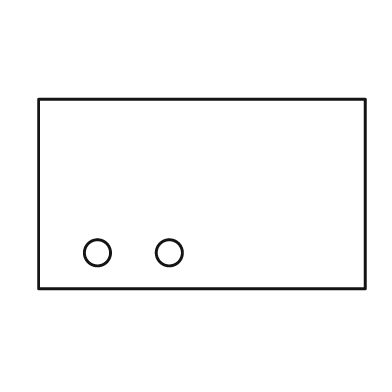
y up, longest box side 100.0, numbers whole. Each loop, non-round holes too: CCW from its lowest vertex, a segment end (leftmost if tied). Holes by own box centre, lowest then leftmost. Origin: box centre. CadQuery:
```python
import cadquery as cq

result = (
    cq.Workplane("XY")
    .moveTo(-50.0, -29.0)
    .lineTo(50.0, -29.0)
    .lineTo(50.0, 29.0)
    .lineTo(-50.0, 29.0)
    .close()
    .moveTo(-32.0, -18.0)
    .circle(4.0)
    .moveTo(-10.0, -18.0)
    .circle(4.0)
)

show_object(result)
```